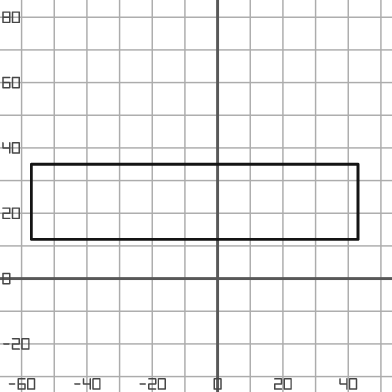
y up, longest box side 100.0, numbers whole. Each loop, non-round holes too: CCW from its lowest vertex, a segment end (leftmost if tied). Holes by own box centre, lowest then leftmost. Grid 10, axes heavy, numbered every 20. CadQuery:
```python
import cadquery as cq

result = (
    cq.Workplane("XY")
    .moveTo(-57.0, 12.0)
    .lineTo(43.0, 12.0)
    .lineTo(43.0, 35.0)
    .lineTo(-57.0, 35.0)
    .close()
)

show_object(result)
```